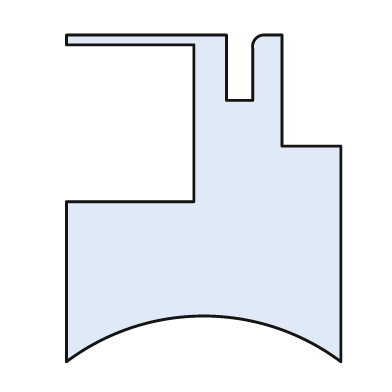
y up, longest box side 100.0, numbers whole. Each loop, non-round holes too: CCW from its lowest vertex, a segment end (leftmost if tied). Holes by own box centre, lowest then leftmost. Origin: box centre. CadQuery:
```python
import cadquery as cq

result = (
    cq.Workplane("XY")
    .moveTo(-42.0, -50.0)
    .threePointArc((0.0, -36.0), (42.0, -50.0))
    .lineTo(42.0, 16.0)
    .lineTo(24.0, 16.0)
    .lineTo(24.0, 50.0)
    .lineTo(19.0, 50.0)
    .threePointArc((16.0, 49.0), (15.0, 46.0))
    .lineTo(15.0, 30.0)
    .lineTo(7.0, 30.0)
    .lineTo(7.0, 50.0)
    .lineTo(-42.0, 50.0)
    .lineTo(-42.0, 47.0)
    .lineTo(-3.0, 47.0)
    .lineTo(-3.0, -1.0)
    .lineTo(-42.0, -1.0)
    .close()
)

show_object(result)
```